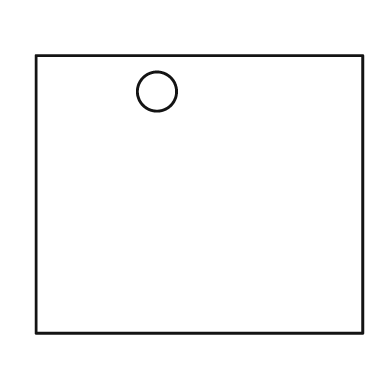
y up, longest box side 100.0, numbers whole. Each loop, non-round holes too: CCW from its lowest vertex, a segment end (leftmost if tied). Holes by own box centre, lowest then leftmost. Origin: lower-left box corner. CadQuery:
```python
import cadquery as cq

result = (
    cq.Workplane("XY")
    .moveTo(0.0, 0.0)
    .lineTo(100.0, 0.0)
    .lineTo(100.0, 85.0)
    .lineTo(0.0, 85.0)
    .close()
    .moveTo(37.0, 74.0)
    .circle(6.0)
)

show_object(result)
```